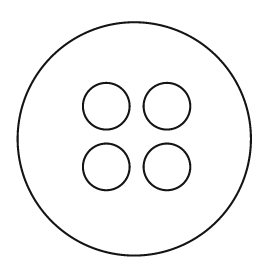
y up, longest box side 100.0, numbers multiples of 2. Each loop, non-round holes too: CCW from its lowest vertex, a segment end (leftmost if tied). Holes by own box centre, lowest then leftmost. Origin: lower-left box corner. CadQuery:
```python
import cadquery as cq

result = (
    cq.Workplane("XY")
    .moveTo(50.0, 50.0)
    .circle(50.0)
    .moveTo(38.0, 38.0)
    .circle(10.0)
    .moveTo(64.0, 38.0)
    .circle(10.0)
    .moveTo(38.0, 64.0)
    .circle(10.0)
    .moveTo(64.0, 64.0)
    .circle(10.0)
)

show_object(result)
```